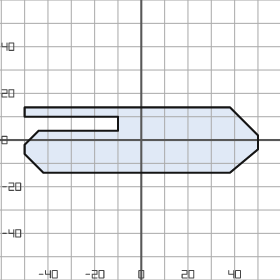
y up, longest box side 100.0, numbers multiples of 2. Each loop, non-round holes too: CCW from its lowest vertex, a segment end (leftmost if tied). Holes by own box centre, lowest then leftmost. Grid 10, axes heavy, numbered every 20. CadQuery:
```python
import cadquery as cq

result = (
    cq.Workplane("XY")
    .moveTo(-42.0, -14.0)
    .lineTo(38.0, -14.0)
    .lineTo(50.0, -4.0)
    .lineTo(50.0, 2.0)
    .lineTo(38.0, 14.0)
    .lineTo(-50.0, 14.0)
    .lineTo(-50.0, 10.0)
    .lineTo(-10.0, 10.0)
    .lineTo(-10.0, 4.0)
    .lineTo(-44.0, 4.0)
    .lineTo(-50.0, -2.0)
    .lineTo(-50.0, -6.0)
    .close()
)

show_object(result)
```